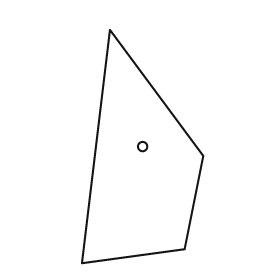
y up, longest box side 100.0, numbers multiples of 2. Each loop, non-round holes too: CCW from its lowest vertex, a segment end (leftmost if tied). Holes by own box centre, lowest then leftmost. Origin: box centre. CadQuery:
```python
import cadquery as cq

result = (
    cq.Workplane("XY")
    .moveTo(-26.0, -50.0)
    .lineTo(18.0, -44.0)
    .lineTo(26.0, -4.0)
    .lineTo(-14.0, 50.0)
    .close()
    .moveTo(0.0, 0.0)
    .circle(2.0)
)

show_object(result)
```